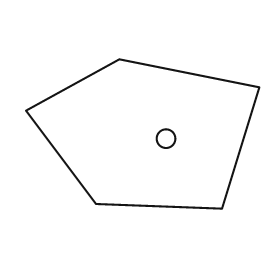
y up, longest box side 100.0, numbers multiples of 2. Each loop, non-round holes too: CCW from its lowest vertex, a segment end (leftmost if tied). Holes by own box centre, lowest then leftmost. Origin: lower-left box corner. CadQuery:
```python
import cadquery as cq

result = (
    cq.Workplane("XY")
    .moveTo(84.0, 0.0)
    .lineTo(100.0, 52.0)
    .lineTo(40.0, 64.0)
    .lineTo(0.0, 42.0)
    .lineTo(30.0, 2.0)
    .close()
    .moveTo(60.0, 30.0)
    .circle(4.0)
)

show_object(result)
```